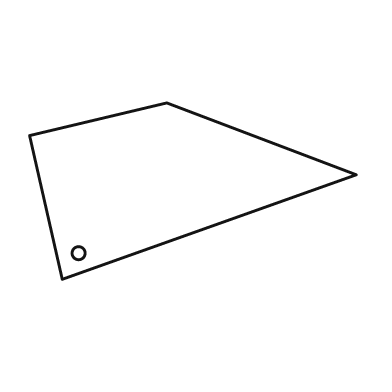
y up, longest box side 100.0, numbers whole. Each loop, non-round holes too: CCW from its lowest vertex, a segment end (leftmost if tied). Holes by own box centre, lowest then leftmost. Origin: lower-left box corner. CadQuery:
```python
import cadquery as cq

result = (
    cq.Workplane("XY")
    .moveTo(10.0, 0.0)
    .lineTo(100.0, 32.0)
    .lineTo(42.0, 54.0)
    .lineTo(0.0, 44.0)
    .close()
    .moveTo(15.0, 8.0)
    .circle(2.0)
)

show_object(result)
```